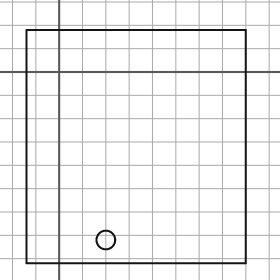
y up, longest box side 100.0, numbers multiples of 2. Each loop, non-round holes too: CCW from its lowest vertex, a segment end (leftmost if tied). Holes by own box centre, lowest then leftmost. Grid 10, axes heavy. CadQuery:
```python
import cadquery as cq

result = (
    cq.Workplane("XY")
    .moveTo(-14.0, -82.0)
    .lineTo(80.0, -82.0)
    .lineTo(80.0, 18.0)
    .lineTo(-14.0, 18.0)
    .close()
    .moveTo(20.0, -72.0)
    .circle(4.0)
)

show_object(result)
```